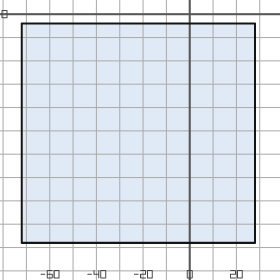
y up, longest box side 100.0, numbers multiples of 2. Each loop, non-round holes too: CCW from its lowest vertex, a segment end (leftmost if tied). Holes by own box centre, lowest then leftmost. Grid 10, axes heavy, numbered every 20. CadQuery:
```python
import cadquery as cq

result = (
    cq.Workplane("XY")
    .moveTo(-72.0, -98.0)
    .lineTo(28.0, -98.0)
    .lineTo(28.0, -4.0)
    .lineTo(-72.0, -4.0)
    .close()
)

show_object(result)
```